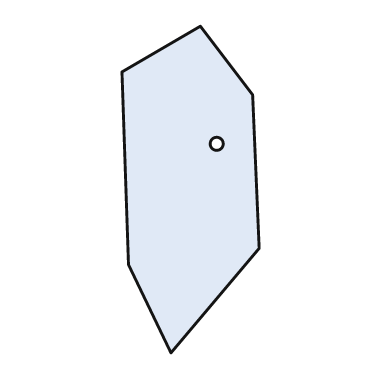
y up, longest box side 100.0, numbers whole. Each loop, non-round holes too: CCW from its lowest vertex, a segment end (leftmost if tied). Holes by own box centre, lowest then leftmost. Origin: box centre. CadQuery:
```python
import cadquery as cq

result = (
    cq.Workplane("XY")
    .moveTo(-6.0, -50.0)
    .lineTo(21.0, -18.0)
    .lineTo(19.0, 29.0)
    .lineTo(3.0, 50.0)
    .lineTo(-21.0, 36.0)
    .lineTo(-19.0, -23.0)
    .close()
    .moveTo(8.0, 14.0)
    .circle(2.0)
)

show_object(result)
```